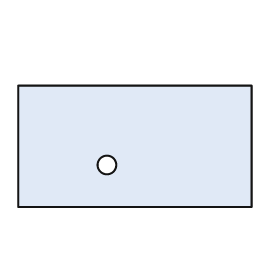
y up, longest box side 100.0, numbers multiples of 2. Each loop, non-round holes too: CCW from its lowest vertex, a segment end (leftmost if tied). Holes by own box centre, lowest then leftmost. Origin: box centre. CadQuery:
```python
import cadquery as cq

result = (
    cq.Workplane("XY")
    .moveTo(-50.0, -26.0)
    .lineTo(50.0, -26.0)
    .lineTo(50.0, 26.0)
    .lineTo(-50.0, 26.0)
    .close()
    .moveTo(-12.0, -8.0)
    .circle(4.0)
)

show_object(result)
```